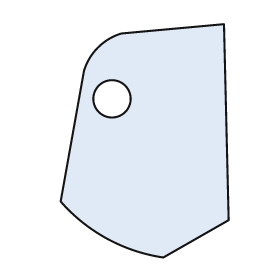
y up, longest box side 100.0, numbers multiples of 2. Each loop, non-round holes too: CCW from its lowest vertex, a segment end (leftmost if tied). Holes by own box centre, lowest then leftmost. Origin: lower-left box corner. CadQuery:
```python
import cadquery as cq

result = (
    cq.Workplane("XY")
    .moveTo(44.0, 0.0)
    .lineTo(72.0, 16.0)
    .lineTo(70.0, 100.0)
    .lineTo(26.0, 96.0)
    .threePointArc((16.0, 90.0), (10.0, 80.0))
    .lineTo(0.0, 24.0)
    .threePointArc((20.0, 8.0), (44.0, 0.0))
    .close()
    .moveTo(22.0, 68.0)
    .circle(8.0)
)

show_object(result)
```